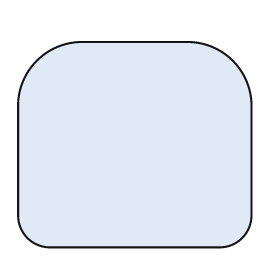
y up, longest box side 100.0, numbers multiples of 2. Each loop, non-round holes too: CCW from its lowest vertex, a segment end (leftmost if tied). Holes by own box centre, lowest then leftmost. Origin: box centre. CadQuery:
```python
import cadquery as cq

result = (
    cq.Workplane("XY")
    .moveTo(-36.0, -44.0)
    .lineTo(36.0, -44.0)
    .threePointArc((46.0, -40.0), (50.0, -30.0))
    .lineTo(50.0, 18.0)
    .threePointArc((42.0, 36.0), (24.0, 44.0))
    .lineTo(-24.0, 44.0)
    .threePointArc((-42.0, 36.0), (-50.0, 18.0))
    .lineTo(-50.0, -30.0)
    .threePointArc((-46.0, -40.0), (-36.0, -44.0))
    .close()
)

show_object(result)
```